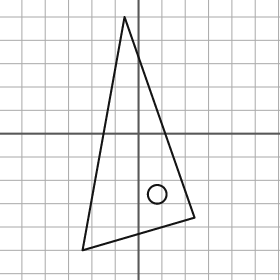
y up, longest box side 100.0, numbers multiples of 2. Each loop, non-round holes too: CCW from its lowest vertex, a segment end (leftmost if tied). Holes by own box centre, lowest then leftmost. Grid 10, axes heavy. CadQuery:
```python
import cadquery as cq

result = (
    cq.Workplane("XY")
    .moveTo(-24.0, -50.0)
    .lineTo(24.0, -36.0)
    .lineTo(-6.0, 50.0)
    .close()
    .moveTo(8.0, -26.0)
    .circle(4.0)
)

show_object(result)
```